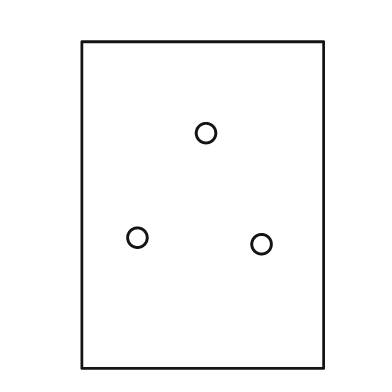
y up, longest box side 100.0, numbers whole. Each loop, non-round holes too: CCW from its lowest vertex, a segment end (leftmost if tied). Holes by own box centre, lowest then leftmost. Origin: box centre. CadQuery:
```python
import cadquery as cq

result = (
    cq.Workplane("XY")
    .moveTo(-37.0, -50.0)
    .lineTo(37.0, -50.0)
    .lineTo(37.0, 50.0)
    .lineTo(-37.0, 50.0)
    .close()
    .moveTo(18.0, -12.0)
    .circle(3.0)
    .moveTo(-20.0, -10.0)
    .circle(3.0)
    .moveTo(1.0, 22.0)
    .circle(3.0)
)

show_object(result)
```